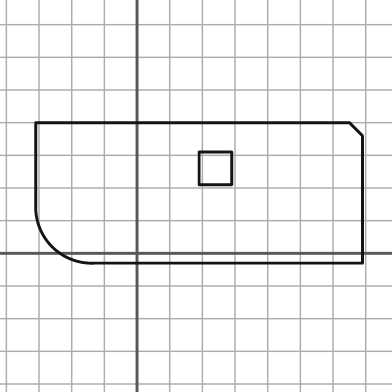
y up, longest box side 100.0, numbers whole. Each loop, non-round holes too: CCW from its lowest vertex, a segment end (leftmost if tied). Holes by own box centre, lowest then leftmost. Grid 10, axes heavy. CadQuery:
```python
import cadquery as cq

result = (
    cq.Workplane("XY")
    .moveTo(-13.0, -3.0)
    .lineTo(69.0, -3.0)
    .lineTo(69.0, 36.0)
    .lineTo(65.0, 40.0)
    .lineTo(-31.0, 40.0)
    .lineTo(-31.0, 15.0)
    .threePointArc((-26.0, 2.0), (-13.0, -3.0))
    .close()
    .moveTo(19.0, 21.0)
    .lineTo(29.0, 21.0)
    .lineTo(29.0, 31.0)
    .lineTo(19.0, 31.0)
    .close()
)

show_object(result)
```